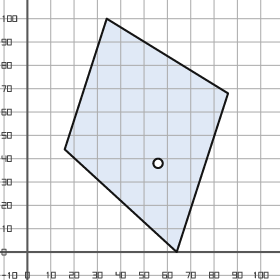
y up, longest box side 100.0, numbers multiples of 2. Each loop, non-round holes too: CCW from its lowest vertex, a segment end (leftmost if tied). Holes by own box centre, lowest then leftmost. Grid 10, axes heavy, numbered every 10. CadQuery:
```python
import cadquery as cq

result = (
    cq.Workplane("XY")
    .moveTo(64.0, 0.0)
    .lineTo(86.0, 68.0)
    .lineTo(34.0, 100.0)
    .lineTo(16.0, 44.0)
    .close()
    .moveTo(56.0, 38.0)
    .circle(2.0)
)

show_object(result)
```